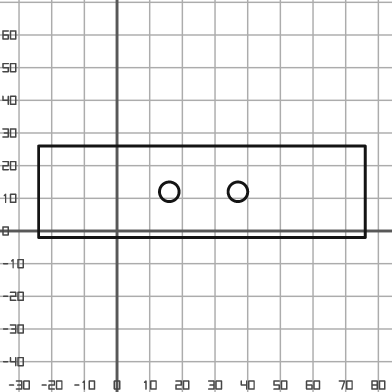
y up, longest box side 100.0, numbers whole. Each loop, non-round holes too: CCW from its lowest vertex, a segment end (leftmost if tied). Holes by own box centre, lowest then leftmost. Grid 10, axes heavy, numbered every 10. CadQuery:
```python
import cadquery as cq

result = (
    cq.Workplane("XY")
    .moveTo(-24.0, -2.0)
    .lineTo(76.0, -2.0)
    .lineTo(76.0, 26.0)
    .lineTo(-24.0, 26.0)
    .close()
    .moveTo(16.0, 12.0)
    .circle(3.0)
    .moveTo(37.0, 12.0)
    .circle(3.0)
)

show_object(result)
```